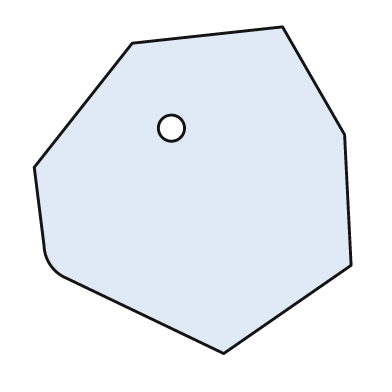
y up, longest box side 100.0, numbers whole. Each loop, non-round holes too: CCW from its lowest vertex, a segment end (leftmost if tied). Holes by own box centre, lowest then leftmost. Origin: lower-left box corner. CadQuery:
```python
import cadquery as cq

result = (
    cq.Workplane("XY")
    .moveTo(58.0, 0.0)
    .lineTo(97.0, 27.0)
    .lineTo(95.0, 67.0)
    .lineTo(76.0, 100.0)
    .lineTo(30.0, 95.0)
    .lineTo(0.0, 57.0)
    .lineTo(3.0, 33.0)
    .threePointArc((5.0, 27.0), (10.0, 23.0))
    .close()
    .moveTo(42.0, 69.0)
    .circle(4.0)
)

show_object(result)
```